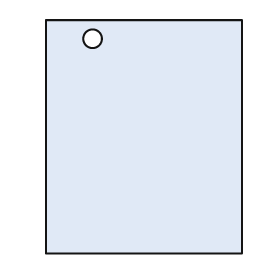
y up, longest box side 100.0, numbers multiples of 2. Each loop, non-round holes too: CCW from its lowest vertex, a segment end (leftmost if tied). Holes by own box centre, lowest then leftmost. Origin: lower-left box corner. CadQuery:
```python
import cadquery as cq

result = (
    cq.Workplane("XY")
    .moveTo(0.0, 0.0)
    .lineTo(84.0, 0.0)
    .lineTo(84.0, 100.0)
    .lineTo(0.0, 100.0)
    .close()
    .moveTo(20.0, 92.0)
    .circle(4.0)
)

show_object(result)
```